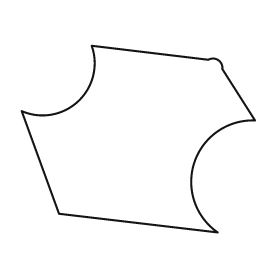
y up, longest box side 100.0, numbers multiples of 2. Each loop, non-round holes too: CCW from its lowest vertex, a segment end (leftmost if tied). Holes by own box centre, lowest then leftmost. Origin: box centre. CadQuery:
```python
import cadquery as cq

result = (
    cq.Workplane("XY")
    .moveTo(34.0, -40.0)
    .threePointArc((24.0, -10.0), (50.0, 8.0))
    .lineTo(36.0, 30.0)
    .threePointArc((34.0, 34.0), (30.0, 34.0))
    .lineTo(-20.0, 40.0)
    .threePointArc((-26.0, 16.0), (-50.0, 12.0))
    .lineTo(-34.0, -32.0)
    .close()
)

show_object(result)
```